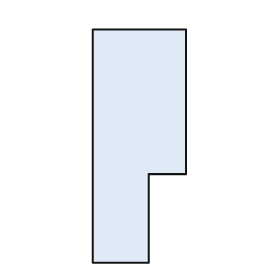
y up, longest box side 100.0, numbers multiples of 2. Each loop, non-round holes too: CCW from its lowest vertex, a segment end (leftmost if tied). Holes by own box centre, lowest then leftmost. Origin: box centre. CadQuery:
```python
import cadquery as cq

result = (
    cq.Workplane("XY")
    .moveTo(-20.0, -50.0)
    .lineTo(4.0, -50.0)
    .lineTo(4.0, -12.0)
    .lineTo(20.0, -12.0)
    .lineTo(20.0, 50.0)
    .lineTo(-20.0, 50.0)
    .close()
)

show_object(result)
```